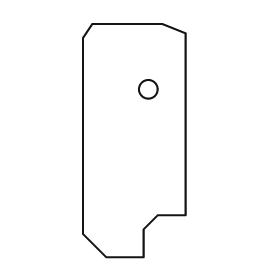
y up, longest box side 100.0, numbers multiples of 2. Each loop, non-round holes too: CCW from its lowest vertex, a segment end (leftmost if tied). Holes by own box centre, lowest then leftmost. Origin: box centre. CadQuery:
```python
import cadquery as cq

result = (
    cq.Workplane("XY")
    .moveTo(-12.0, -50.0)
    .lineTo(4.0, -50.0)
    .lineTo(4.0, -38.0)
    .lineTo(10.0, -32.0)
    .lineTo(22.0, -32.0)
    .lineTo(22.0, 46.0)
    .lineTo(12.0, 50.0)
    .lineTo(-18.0, 50.0)
    .lineTo(-22.0, 44.0)
    .lineTo(-22.0, -40.0)
    .close()
    .moveTo(6.0, 22.0)
    .circle(4.0)
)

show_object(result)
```